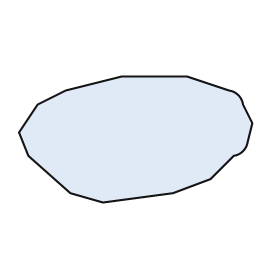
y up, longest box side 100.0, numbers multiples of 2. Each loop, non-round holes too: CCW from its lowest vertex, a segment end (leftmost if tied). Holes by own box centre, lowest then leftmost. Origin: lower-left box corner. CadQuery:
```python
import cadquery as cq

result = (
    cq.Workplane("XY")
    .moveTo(36.0, 0.0)
    .lineTo(66.0, 4.0)
    .lineTo(82.0, 10.0)
    .lineTo(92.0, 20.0)
    .threePointArc((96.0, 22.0), (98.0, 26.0))
    .lineTo(100.0, 34.0)
    .lineTo(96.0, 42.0)
    .threePointArc((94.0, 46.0), (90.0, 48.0))
    .lineTo(72.0, 54.0)
    .lineTo(44.0, 54.0)
    .lineTo(20.0, 48.0)
    .lineTo(8.0, 42.0)
    .lineTo(0.0, 30.0)
    .lineTo(4.0, 20.0)
    .lineTo(22.0, 4.0)
    .close()
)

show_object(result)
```